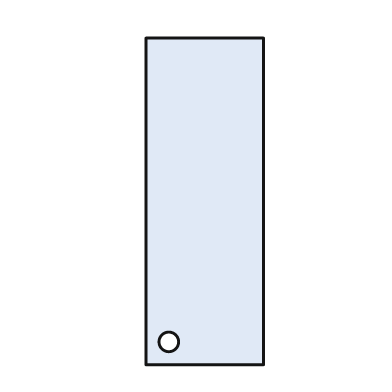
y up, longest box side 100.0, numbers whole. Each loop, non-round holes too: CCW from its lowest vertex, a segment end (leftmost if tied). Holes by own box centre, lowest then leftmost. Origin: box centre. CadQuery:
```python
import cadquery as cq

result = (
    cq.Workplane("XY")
    .moveTo(-18.0, -50.0)
    .lineTo(18.0, -50.0)
    .lineTo(18.0, 50.0)
    .lineTo(-18.0, 50.0)
    .close()
    .moveTo(-11.0, -43.0)
    .circle(3.0)
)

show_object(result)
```